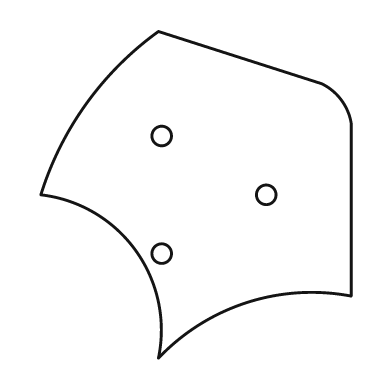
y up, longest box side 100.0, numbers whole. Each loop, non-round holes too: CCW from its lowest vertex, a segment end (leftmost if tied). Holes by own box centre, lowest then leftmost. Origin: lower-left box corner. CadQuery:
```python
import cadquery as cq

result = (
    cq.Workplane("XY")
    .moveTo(36.0, 0.0)
    .threePointArc((63.0, 17.0), (95.0, 19.0))
    .lineTo(95.0, 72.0)
    .threePointArc((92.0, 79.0), (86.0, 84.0))
    .lineTo(36.0, 100.0)
    .threePointArc((14.0, 78.0), (0.0, 50.0))
    .threePointArc((29.0, 33.0), (36.0, 0.0))
    .close()
    .moveTo(37.0, 32.0)
    .circle(3.0)
    .moveTo(69.0, 50.0)
    .circle(3.0)
    .moveTo(37.0, 68.0)
    .circle(3.0)
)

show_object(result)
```